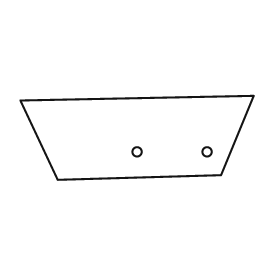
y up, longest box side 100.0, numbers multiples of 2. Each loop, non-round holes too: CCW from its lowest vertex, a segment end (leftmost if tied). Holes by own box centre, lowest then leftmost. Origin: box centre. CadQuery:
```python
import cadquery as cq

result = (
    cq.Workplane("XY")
    .moveTo(-34.0, -18.0)
    .lineTo(36.0, -16.0)
    .lineTo(50.0, 18.0)
    .lineTo(-50.0, 16.0)
    .close()
    .moveTo(0.0, -6.0)
    .circle(2.0)
    .moveTo(30.0, -6.0)
    .circle(2.0)
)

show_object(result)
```